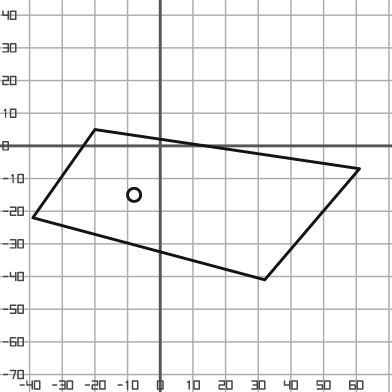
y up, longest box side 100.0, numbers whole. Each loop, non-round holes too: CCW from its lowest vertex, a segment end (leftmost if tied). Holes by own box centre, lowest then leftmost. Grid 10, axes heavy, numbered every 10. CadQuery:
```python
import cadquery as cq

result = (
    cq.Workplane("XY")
    .moveTo(32.0, -41.0)
    .lineTo(61.0, -7.0)
    .lineTo(-20.0, 5.0)
    .lineTo(-39.0, -22.0)
    .close()
    .moveTo(-8.0, -15.0)
    .circle(2.0)
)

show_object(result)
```